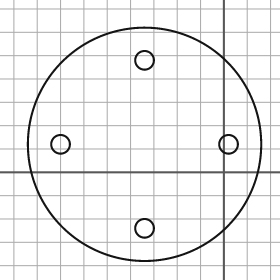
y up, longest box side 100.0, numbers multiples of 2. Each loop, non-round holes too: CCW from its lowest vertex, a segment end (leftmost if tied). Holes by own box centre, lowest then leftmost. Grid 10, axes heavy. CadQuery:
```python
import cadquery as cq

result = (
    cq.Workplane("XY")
    .moveTo(-34.0, 12.0)
    .circle(50.0)
    .moveTo(-34.0, -24.0)
    .circle(4.0)
    .moveTo(-70.0, 12.0)
    .circle(4.0)
    .moveTo(2.0, 12.0)
    .circle(4.0)
    .moveTo(-34.0, 48.0)
    .circle(4.0)
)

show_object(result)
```